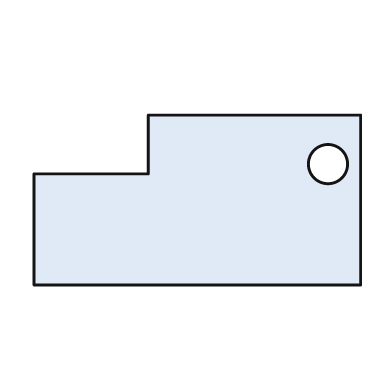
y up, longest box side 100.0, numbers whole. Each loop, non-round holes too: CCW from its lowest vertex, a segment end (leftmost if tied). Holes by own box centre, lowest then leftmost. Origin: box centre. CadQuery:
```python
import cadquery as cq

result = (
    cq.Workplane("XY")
    .moveTo(-50.0, -26.0)
    .lineTo(50.0, -26.0)
    .lineTo(50.0, 26.0)
    .lineTo(-15.0, 26.0)
    .lineTo(-15.0, 8.0)
    .lineTo(-50.0, 8.0)
    .close()
    .moveTo(40.0, 11.0)
    .circle(6.0)
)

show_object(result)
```